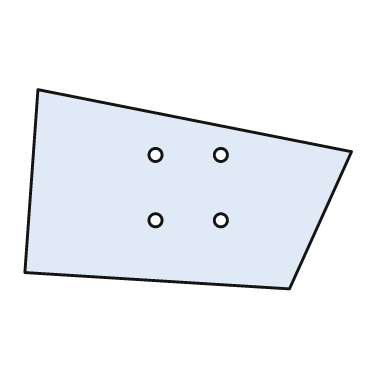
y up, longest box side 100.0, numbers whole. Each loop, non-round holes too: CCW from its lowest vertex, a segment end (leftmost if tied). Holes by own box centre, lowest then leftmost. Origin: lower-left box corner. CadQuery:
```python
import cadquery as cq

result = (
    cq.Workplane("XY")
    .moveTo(81.0, 0.0)
    .lineTo(100.0, 42.0)
    .lineTo(4.0, 61.0)
    .lineTo(0.0, 5.0)
    .close()
    .moveTo(40.0, 21.0)
    .circle(2.0)
    .moveTo(60.0, 21.0)
    .circle(2.0)
    .moveTo(40.0, 41.0)
    .circle(2.0)
    .moveTo(60.0, 41.0)
    .circle(2.0)
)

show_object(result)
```